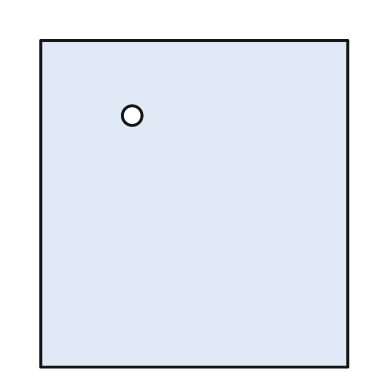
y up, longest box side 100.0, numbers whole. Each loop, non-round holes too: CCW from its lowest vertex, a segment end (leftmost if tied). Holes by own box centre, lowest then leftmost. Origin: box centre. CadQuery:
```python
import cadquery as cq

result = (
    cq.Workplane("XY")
    .moveTo(-47.0, -50.0)
    .lineTo(47.0, -50.0)
    .lineTo(47.0, 50.0)
    .lineTo(-47.0, 50.0)
    .close()
    .moveTo(-19.0, 27.0)
    .circle(3.0)
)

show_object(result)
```